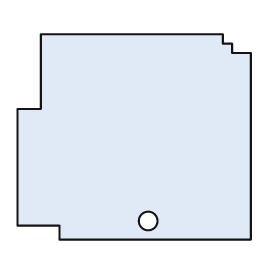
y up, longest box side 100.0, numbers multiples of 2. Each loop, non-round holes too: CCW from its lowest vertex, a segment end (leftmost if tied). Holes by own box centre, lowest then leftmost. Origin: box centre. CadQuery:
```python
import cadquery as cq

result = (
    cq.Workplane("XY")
    .moveTo(-32.0, -44.0)
    .lineTo(50.0, -44.0)
    .lineTo(50.0, 36.0)
    .lineTo(42.0, 36.0)
    .lineTo(42.0, 40.0)
    .lineTo(38.0, 40.0)
    .lineTo(38.0, 44.0)
    .lineTo(-40.0, 44.0)
    .lineTo(-40.0, 12.0)
    .lineTo(-50.0, 12.0)
    .lineTo(-50.0, -38.0)
    .lineTo(-32.0, -38.0)
    .close()
    .moveTo(6.0, -36.0)
    .circle(4.0)
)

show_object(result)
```